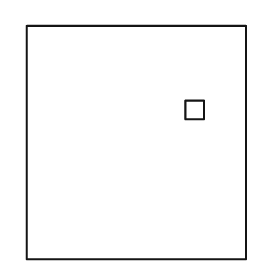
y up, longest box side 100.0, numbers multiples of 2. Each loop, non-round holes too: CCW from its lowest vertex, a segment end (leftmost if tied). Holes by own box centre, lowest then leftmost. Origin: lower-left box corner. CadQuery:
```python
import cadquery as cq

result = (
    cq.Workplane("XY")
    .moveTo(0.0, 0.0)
    .lineTo(94.0, 0.0)
    .lineTo(94.0, 100.0)
    .lineTo(0.0, 100.0)
    .close()
    .moveTo(68.0, 60.0)
    .lineTo(76.0, 60.0)
    .lineTo(76.0, 68.0)
    .lineTo(68.0, 68.0)
    .close()
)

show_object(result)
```